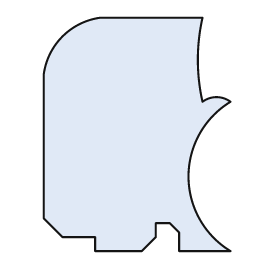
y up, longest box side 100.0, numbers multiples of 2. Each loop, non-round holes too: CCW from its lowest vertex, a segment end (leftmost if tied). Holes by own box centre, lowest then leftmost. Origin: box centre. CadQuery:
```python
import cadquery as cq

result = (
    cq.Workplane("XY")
    .moveTo(-18.0, -50.0)
    .lineTo(2.0, -50.0)
    .lineTo(8.0, -44.0)
    .lineTo(8.0, -38.0)
    .lineTo(14.0, -38.0)
    .lineTo(18.0, -42.0)
    .lineTo(18.0, -50.0)
    .lineTo(40.0, -50.0)
    .threePointArc((22.0, -18.0), (40.0, 14.0))
    .threePointArc((34.0, 16.0), (28.0, 14.0))
    .threePointArc((26.0, 32.0), (28.0, 50.0))
    .lineTo(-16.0, 50.0)
    .threePointArc((-32.0, 42.0), (-40.0, 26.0))
    .lineTo(-40.0, -36.0)
    .lineTo(-32.0, -44.0)
    .lineTo(-18.0, -44.0)
    .close()
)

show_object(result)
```